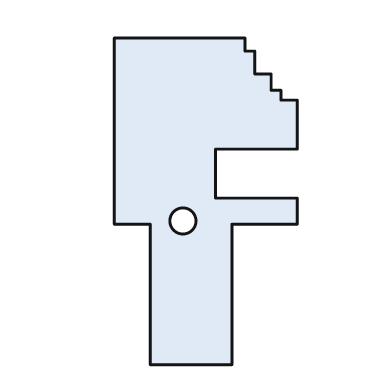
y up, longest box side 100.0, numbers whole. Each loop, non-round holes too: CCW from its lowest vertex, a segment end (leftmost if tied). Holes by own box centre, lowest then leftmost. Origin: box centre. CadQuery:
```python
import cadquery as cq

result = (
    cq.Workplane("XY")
    .moveTo(-17.0, -50.0)
    .lineTo(8.0, -50.0)
    .lineTo(8.0, -7.0)
    .lineTo(28.0, -7.0)
    .lineTo(28.0, 1.0)
    .lineTo(3.0, 1.0)
    .lineTo(3.0, 16.0)
    .lineTo(28.0, 16.0)
    .lineTo(28.0, 31.0)
    .lineTo(23.0, 31.0)
    .lineTo(23.0, 34.0)
    .lineTo(20.0, 34.0)
    .lineTo(20.0, 39.0)
    .lineTo(15.0, 39.0)
    .lineTo(15.0, 46.0)
    .lineTo(12.0, 46.0)
    .lineTo(12.0, 50.0)
    .lineTo(-28.0, 50.0)
    .lineTo(-28.0, -7.0)
    .lineTo(-17.0, -7.0)
    .close()
    .moveTo(-7.0, -6.0)
    .circle(4.0)
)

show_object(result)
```